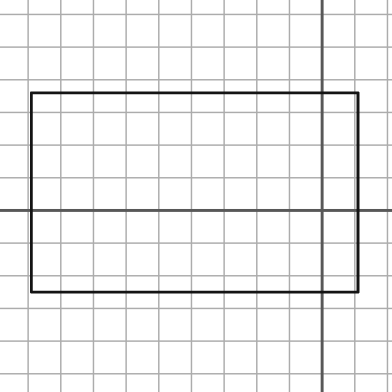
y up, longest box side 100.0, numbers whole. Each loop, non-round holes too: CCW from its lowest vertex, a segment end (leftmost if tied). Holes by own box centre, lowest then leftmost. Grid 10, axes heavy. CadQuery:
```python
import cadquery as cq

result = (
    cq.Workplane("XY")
    .moveTo(-89.0, -25.0)
    .lineTo(11.0, -25.0)
    .lineTo(11.0, 36.0)
    .lineTo(-89.0, 36.0)
    .close()
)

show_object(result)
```